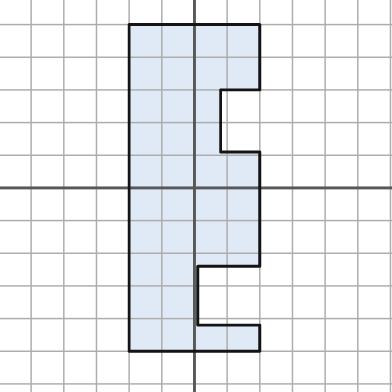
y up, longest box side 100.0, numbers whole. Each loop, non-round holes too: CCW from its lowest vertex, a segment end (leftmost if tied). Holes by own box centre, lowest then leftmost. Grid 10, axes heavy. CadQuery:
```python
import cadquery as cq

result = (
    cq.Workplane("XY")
    .moveTo(-20.0, -50.0)
    .lineTo(20.0, -50.0)
    .lineTo(20.0, -42.0)
    .lineTo(1.0, -42.0)
    .lineTo(1.0, -24.0)
    .lineTo(20.0, -24.0)
    .lineTo(20.0, 11.0)
    .lineTo(8.0, 11.0)
    .lineTo(8.0, 30.0)
    .lineTo(20.0, 30.0)
    .lineTo(20.0, 50.0)
    .lineTo(-20.0, 50.0)
    .close()
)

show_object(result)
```